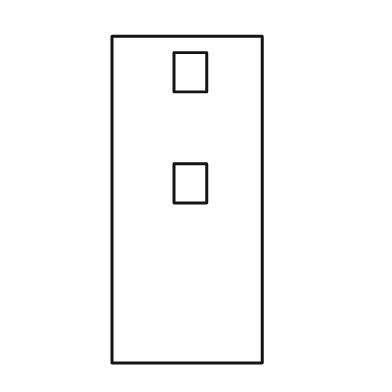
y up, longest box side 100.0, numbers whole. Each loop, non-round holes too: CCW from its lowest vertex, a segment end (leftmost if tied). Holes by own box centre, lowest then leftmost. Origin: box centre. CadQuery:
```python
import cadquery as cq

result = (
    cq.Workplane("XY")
    .moveTo(-23.0, -50.0)
    .lineTo(23.0, -50.0)
    .lineTo(23.0, 50.0)
    .lineTo(-23.0, 50.0)
    .close()
    .moveTo(-4.0, -1.0)
    .lineTo(6.0, -1.0)
    .lineTo(6.0, 11.0)
    .lineTo(-4.0, 11.0)
    .close()
    .moveTo(-4.0, 33.0)
    .lineTo(6.0, 33.0)
    .lineTo(6.0, 45.0)
    .lineTo(-4.0, 45.0)
    .close()
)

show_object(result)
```